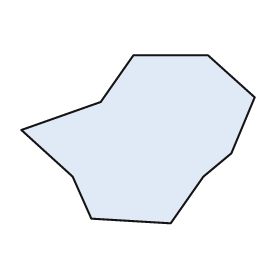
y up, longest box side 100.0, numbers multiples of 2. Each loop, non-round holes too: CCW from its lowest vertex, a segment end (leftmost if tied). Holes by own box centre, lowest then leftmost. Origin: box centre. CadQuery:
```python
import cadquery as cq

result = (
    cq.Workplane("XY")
    .moveTo(14.0, -36.0)
    .lineTo(28.0, -16.0)
    .lineTo(40.0, -6.0)
    .lineTo(50.0, 18.0)
    .lineTo(30.0, 36.0)
    .lineTo(-2.0, 36.0)
    .lineTo(-16.0, 16.0)
    .lineTo(-50.0, 4.0)
    .lineTo(-28.0, -16.0)
    .lineTo(-20.0, -34.0)
    .close()
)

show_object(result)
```